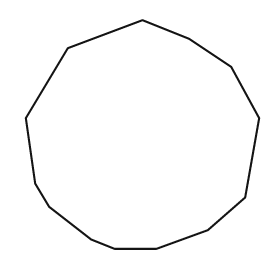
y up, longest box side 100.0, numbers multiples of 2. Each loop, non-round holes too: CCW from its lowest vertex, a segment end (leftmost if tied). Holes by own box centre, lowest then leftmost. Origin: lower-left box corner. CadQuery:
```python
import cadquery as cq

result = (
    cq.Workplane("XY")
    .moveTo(38.0, 0.0)
    .lineTo(56.0, 0.0)
    .lineTo(78.0, 8.0)
    .lineTo(94.0, 22.0)
    .lineTo(100.0, 56.0)
    .lineTo(88.0, 78.0)
    .lineTo(70.0, 90.0)
    .lineTo(50.0, 98.0)
    .lineTo(18.0, 86.0)
    .lineTo(0.0, 56.0)
    .lineTo(4.0, 28.0)
    .lineTo(10.0, 18.0)
    .lineTo(28.0, 4.0)
    .close()
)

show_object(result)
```